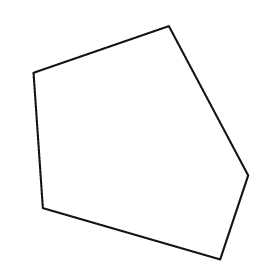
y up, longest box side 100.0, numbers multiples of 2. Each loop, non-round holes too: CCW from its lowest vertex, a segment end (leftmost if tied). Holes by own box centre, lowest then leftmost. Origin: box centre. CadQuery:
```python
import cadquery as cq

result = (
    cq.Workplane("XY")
    .moveTo(34.0, -50.0)
    .lineTo(46.0, -14.0)
    .lineTo(12.0, 50.0)
    .lineTo(-46.0, 30.0)
    .lineTo(-42.0, -28.0)
    .close()
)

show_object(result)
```